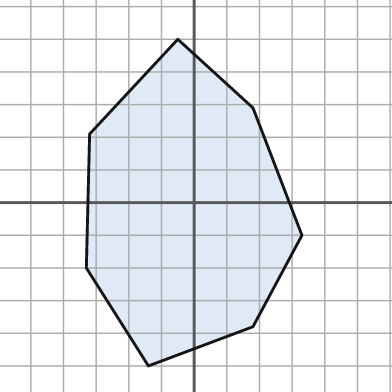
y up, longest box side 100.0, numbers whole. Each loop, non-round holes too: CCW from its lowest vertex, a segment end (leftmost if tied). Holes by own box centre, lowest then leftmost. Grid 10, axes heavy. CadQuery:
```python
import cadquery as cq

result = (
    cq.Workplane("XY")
    .moveTo(-14.0, -50.0)
    .lineTo(18.0, -38.0)
    .lineTo(33.0, -10.0)
    .lineTo(18.0, 29.0)
    .lineTo(-5.0, 50.0)
    .lineTo(-32.0, 21.0)
    .lineTo(-33.0, -20.0)
    .close()
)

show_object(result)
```